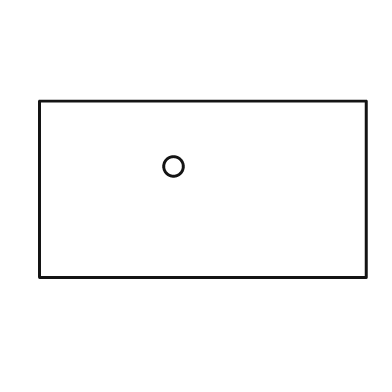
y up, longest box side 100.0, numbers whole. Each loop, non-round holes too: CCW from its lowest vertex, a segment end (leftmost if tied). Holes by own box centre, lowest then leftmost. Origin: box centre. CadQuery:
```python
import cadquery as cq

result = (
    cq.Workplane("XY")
    .moveTo(-50.0, -27.0)
    .lineTo(50.0, -27.0)
    .lineTo(50.0, 27.0)
    .lineTo(-50.0, 27.0)
    .close()
    .moveTo(-9.0, 7.0)
    .circle(3.0)
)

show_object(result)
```